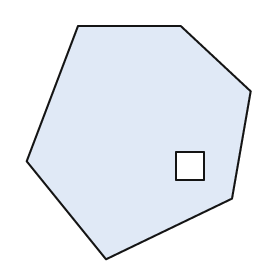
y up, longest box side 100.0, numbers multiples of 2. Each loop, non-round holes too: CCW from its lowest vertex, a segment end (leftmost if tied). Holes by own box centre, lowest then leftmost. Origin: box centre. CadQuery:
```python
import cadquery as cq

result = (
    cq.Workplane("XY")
    .moveTo(-14.0, -50.0)
    .lineTo(40.0, -24.0)
    .lineTo(48.0, 22.0)
    .lineTo(18.0, 50.0)
    .lineTo(-26.0, 50.0)
    .lineTo(-48.0, -8.0)
    .close()
    .moveTo(16.0, -16.0)
    .lineTo(28.0, -16.0)
    .lineTo(28.0, -4.0)
    .lineTo(16.0, -4.0)
    .close()
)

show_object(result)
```